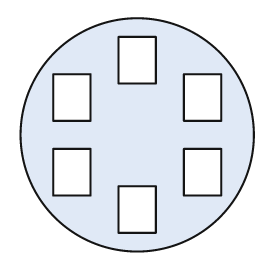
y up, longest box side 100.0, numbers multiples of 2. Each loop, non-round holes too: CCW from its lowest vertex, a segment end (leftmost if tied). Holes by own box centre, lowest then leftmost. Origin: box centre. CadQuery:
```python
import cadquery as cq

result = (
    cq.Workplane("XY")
    .moveTo(0.0, 0.0)
    .circle(50.0)
    .moveTo(-8.0, -42.0)
    .lineTo(8.0, -42.0)
    .lineTo(8.0, -22.0)
    .lineTo(-8.0, -22.0)
    .close()
    .moveTo(-36.0, -26.0)
    .lineTo(-20.0, -26.0)
    .lineTo(-20.0, -6.0)
    .lineTo(-36.0, -6.0)
    .close()
    .moveTo(20.0, -26.0)
    .lineTo(36.0, -26.0)
    .lineTo(36.0, -6.0)
    .lineTo(20.0, -6.0)
    .close()
    .moveTo(-36.0, 6.0)
    .lineTo(-20.0, 6.0)
    .lineTo(-20.0, 26.0)
    .lineTo(-36.0, 26.0)
    .close()
    .moveTo(20.0, 6.0)
    .lineTo(36.0, 6.0)
    .lineTo(36.0, 26.0)
    .lineTo(20.0, 26.0)
    .close()
    .moveTo(-8.0, 22.0)
    .lineTo(8.0, 22.0)
    .lineTo(8.0, 42.0)
    .lineTo(-8.0, 42.0)
    .close()
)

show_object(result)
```